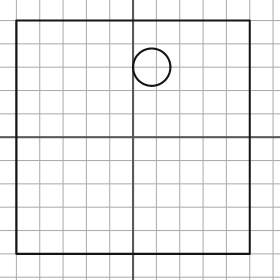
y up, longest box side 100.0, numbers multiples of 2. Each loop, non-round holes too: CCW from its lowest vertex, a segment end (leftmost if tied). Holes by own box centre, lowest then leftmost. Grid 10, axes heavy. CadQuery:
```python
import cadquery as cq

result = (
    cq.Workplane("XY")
    .moveTo(-50.0, -50.0)
    .lineTo(50.0, -50.0)
    .lineTo(50.0, 50.0)
    .lineTo(-50.0, 50.0)
    .close()
    .moveTo(8.0, 30.0)
    .circle(8.0)
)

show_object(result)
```